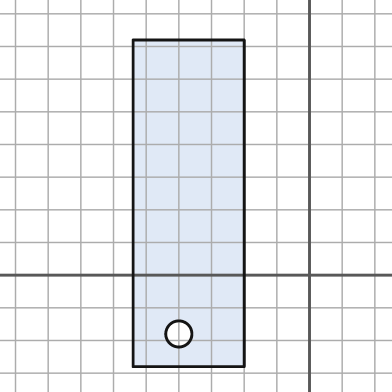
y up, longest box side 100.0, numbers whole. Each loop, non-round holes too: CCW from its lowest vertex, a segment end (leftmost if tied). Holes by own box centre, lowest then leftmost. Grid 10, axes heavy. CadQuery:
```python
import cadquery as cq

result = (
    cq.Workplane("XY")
    .moveTo(-54.0, -28.0)
    .lineTo(-20.0, -28.0)
    .lineTo(-20.0, 72.0)
    .lineTo(-54.0, 72.0)
    .close()
    .moveTo(-40.0, -18.0)
    .circle(4.0)
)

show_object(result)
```